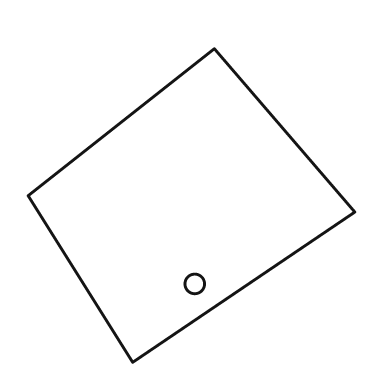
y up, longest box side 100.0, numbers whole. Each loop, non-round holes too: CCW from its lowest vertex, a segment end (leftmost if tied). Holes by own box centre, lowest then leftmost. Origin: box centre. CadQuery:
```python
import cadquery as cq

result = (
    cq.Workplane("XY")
    .moveTo(-18.0, -48.0)
    .lineTo(50.0, -2.0)
    .lineTo(7.0, 48.0)
    .lineTo(-50.0, 3.0)
    .close()
    .moveTo(1.0, -24.0)
    .circle(3.0)
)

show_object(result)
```